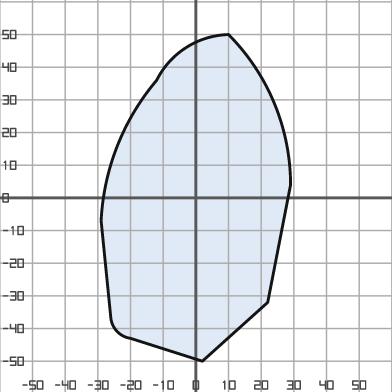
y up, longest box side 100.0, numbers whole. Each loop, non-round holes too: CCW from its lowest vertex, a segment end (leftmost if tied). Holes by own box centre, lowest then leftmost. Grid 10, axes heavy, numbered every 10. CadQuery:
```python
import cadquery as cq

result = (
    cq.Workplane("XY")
    .moveTo(2.0, -50.0)
    .lineTo(22.0, -32.0)
    .lineTo(29.0, 4.0)
    .threePointArc((24.0, 29.0), (10.0, 50.0))
    .threePointArc((-3.0, 46.0), (-12.0, 36.0))
    .threePointArc((-24.0, 16.0), (-29.0, -7.0))
    .lineTo(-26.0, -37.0)
    .threePointArc((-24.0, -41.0), (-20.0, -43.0))
    .close()
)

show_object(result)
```